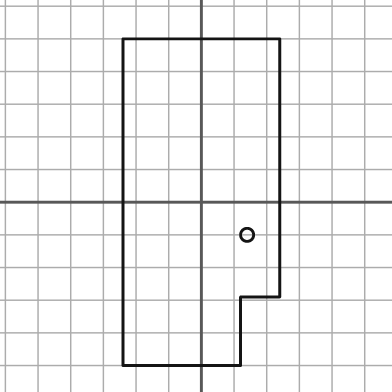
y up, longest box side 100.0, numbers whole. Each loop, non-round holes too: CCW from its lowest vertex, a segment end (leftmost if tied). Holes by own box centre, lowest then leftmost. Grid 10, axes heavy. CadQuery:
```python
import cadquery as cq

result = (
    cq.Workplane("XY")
    .moveTo(-24.0, -50.0)
    .lineTo(12.0, -50.0)
    .lineTo(12.0, -29.0)
    .lineTo(24.0, -29.0)
    .lineTo(24.0, 50.0)
    .lineTo(-24.0, 50.0)
    .close()
    .moveTo(14.0, -10.0)
    .circle(2.0)
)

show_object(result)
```